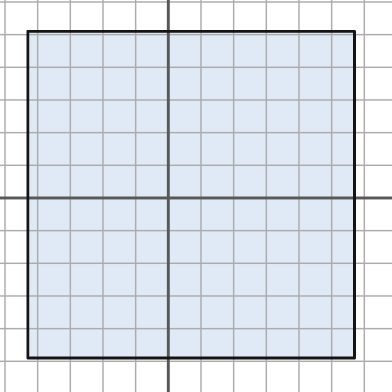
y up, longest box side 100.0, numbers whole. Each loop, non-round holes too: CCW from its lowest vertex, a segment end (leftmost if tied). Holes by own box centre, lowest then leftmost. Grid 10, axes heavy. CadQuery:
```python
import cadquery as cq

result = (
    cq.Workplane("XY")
    .moveTo(-43.0, -49.0)
    .lineTo(57.0, -49.0)
    .lineTo(57.0, 51.0)
    .lineTo(-43.0, 51.0)
    .close()
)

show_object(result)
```